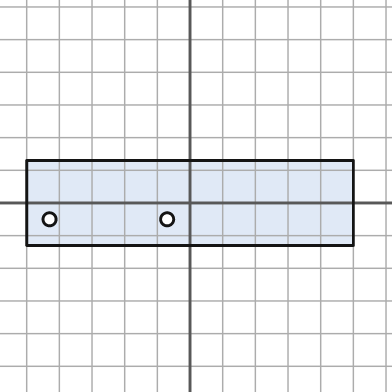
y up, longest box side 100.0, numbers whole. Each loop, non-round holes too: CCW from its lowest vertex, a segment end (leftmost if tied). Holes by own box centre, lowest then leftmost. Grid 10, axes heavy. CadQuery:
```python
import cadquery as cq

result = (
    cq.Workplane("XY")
    .moveTo(-50.0, -13.0)
    .lineTo(50.0, -13.0)
    .lineTo(50.0, 13.0)
    .lineTo(-50.0, 13.0)
    .close()
    .moveTo(-43.0, -5.0)
    .circle(2.0)
    .moveTo(-7.0, -5.0)
    .circle(2.0)
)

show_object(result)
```